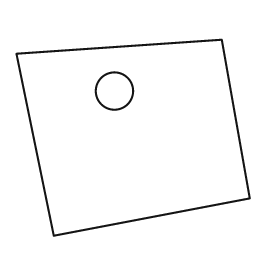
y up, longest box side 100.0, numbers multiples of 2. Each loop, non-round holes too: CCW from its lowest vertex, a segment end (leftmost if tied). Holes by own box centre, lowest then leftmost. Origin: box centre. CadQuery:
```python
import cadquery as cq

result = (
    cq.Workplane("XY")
    .moveTo(-34.0, -42.0)
    .lineTo(50.0, -26.0)
    .lineTo(38.0, 42.0)
    .lineTo(-50.0, 36.0)
    .close()
    .moveTo(-8.0, 20.0)
    .circle(8.0)
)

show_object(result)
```